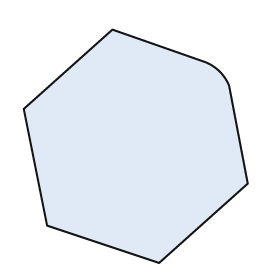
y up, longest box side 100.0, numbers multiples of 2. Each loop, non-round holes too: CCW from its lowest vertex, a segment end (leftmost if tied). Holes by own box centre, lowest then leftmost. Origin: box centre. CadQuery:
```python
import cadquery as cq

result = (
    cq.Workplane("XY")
    .moveTo(10.0, -50.0)
    .lineTo(48.0, -16.0)
    .lineTo(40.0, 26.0)
    .threePointArc((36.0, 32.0), (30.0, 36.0))
    .lineTo(-10.0, 50.0)
    .lineTo(-48.0, 16.0)
    .lineTo(-38.0, -34.0)
    .close()
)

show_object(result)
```